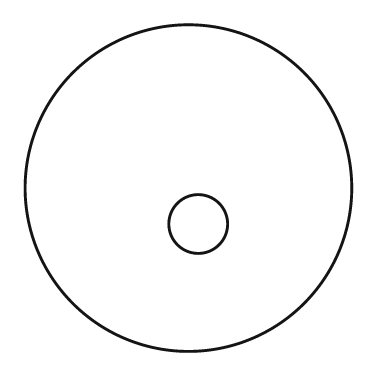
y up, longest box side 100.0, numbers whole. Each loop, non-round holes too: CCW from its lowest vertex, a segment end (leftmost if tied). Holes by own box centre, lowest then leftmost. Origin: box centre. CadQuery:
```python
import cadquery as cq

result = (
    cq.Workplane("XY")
    .moveTo(0.0, 0.0)
    .circle(50.0)
    .moveTo(3.0, -11.0)
    .circle(9.0)
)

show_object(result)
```